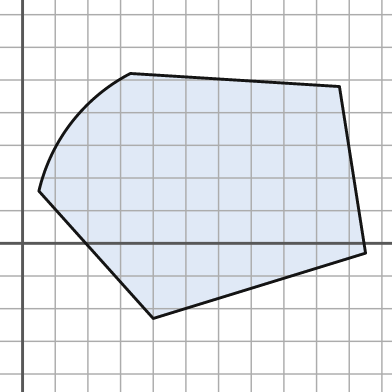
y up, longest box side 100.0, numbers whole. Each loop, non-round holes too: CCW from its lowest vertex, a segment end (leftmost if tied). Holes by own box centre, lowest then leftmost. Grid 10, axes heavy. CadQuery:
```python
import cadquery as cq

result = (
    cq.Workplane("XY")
    .moveTo(40.0, -23.0)
    .lineTo(105.0, -3.0)
    .lineTo(97.0, 48.0)
    .lineTo(33.0, 52.0)
    .threePointArc((15.0, 37.0), (5.0, 16.0))
    .close()
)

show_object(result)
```